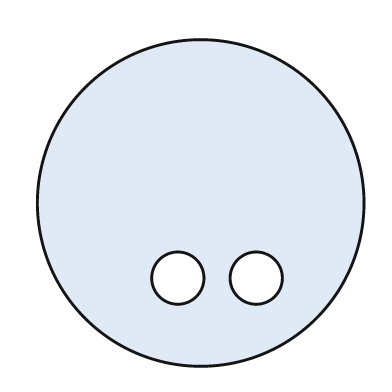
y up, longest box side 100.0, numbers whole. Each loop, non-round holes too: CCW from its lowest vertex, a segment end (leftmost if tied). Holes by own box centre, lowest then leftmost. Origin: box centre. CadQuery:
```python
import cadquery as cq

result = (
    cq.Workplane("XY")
    .moveTo(0.0, 0.0)
    .circle(50.0)
    .moveTo(-7.0, -23.0)
    .circle(8.0)
    .moveTo(17.0, -23.0)
    .circle(8.0)
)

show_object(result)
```